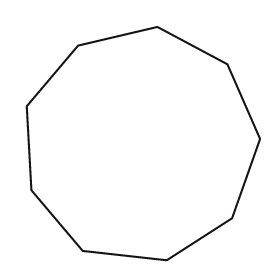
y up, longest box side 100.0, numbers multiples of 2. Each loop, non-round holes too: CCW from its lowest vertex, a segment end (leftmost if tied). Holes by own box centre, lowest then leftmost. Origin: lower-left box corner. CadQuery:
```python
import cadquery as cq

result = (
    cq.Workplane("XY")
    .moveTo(60.0, 0.0)
    .lineTo(88.0, 18.0)
    .lineTo(100.0, 52.0)
    .lineTo(86.0, 84.0)
    .lineTo(56.0, 100.0)
    .lineTo(22.0, 92.0)
    .lineTo(0.0, 66.0)
    .lineTo(2.0, 30.0)
    .lineTo(24.0, 4.0)
    .close()
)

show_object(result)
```